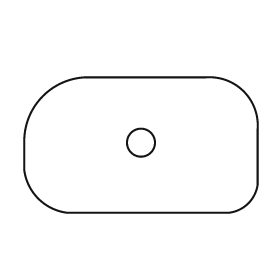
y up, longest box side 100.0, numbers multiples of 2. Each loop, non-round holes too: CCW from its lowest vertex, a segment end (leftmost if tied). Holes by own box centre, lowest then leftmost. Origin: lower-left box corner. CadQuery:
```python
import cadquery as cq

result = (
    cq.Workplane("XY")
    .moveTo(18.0, 0.0)
    .lineTo(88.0, 0.0)
    .threePointArc((96.0, 4.0), (100.0, 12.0))
    .lineTo(100.0, 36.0)
    .threePointArc((94.0, 52.0), (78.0, 58.0))
    .lineTo(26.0, 58.0)
    .threePointArc((8.0, 50.0), (0.0, 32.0))
    .lineTo(0.0, 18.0)
    .threePointArc((6.0, 6.0), (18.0, 0.0))
    .close()
    .moveTo(50.0, 30.0)
    .circle(6.0)
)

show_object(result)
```